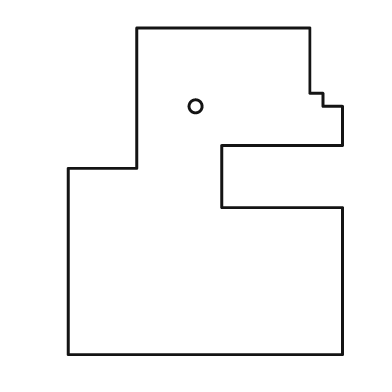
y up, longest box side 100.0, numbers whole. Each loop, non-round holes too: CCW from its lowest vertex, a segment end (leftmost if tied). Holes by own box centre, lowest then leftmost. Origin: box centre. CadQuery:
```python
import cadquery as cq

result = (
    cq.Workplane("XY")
    .moveTo(-42.0, -50.0)
    .lineTo(42.0, -50.0)
    .lineTo(42.0, -5.0)
    .lineTo(5.0, -5.0)
    .lineTo(5.0, 14.0)
    .lineTo(42.0, 14.0)
    .lineTo(42.0, 26.0)
    .lineTo(36.0, 26.0)
    .lineTo(36.0, 30.0)
    .lineTo(32.0, 30.0)
    .lineTo(32.0, 50.0)
    .lineTo(-21.0, 50.0)
    .lineTo(-21.0, 7.0)
    .lineTo(-42.0, 7.0)
    .close()
    .moveTo(-3.0, 26.0)
    .circle(2.0)
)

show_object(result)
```